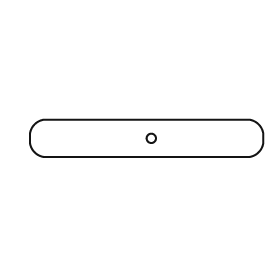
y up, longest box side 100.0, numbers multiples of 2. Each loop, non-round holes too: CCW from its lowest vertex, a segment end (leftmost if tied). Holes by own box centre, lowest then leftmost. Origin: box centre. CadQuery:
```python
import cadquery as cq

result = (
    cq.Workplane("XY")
    .moveTo(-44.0, -8.0)
    .lineTo(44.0, -8.0)
    .threePointArc((48.0, -6.0), (50.0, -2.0))
    .lineTo(50.0, 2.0)
    .threePointArc((48.0, 6.0), (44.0, 8.0))
    .lineTo(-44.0, 8.0)
    .threePointArc((-48.0, 6.0), (-50.0, 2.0))
    .lineTo(-50.0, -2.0)
    .threePointArc((-48.0, -6.0), (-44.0, -8.0))
    .close()
    .moveTo(2.0, 0.0)
    .circle(2.0)
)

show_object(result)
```